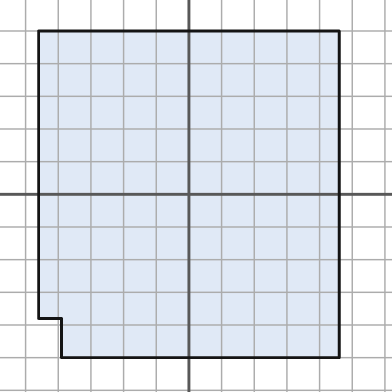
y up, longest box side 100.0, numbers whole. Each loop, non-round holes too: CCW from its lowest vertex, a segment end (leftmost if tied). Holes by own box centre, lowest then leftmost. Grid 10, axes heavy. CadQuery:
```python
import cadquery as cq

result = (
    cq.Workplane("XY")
    .moveTo(-39.0, -50.0)
    .lineTo(46.0, -50.0)
    .lineTo(46.0, 50.0)
    .lineTo(-46.0, 50.0)
    .lineTo(-46.0, -38.0)
    .lineTo(-39.0, -38.0)
    .close()
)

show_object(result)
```